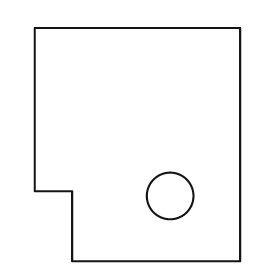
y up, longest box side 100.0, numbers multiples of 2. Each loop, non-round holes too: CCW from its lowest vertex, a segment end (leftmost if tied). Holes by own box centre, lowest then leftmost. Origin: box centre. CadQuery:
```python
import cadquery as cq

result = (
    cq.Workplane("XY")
    .moveTo(-28.0, -50.0)
    .lineTo(44.0, -50.0)
    .lineTo(44.0, 50.0)
    .lineTo(-44.0, 50.0)
    .lineTo(-44.0, -20.0)
    .lineTo(-28.0, -20.0)
    .close()
    .moveTo(14.0, -22.0)
    .circle(10.0)
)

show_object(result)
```